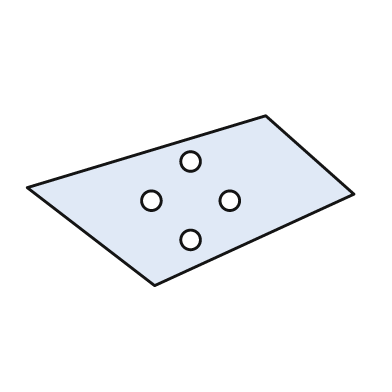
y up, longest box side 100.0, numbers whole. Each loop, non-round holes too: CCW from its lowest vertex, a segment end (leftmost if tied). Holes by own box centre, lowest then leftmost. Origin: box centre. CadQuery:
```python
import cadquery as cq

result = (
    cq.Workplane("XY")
    .moveTo(-11.0, -26.0)
    .lineTo(50.0, 2.0)
    .lineTo(23.0, 26.0)
    .lineTo(-50.0, 4.0)
    .close()
    .moveTo(0.0, -12.0)
    .circle(3.0)
    .moveTo(-12.0, 0.0)
    .circle(3.0)
    .moveTo(12.0, 0.0)
    .circle(3.0)
    .moveTo(0.0, 12.0)
    .circle(3.0)
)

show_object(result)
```